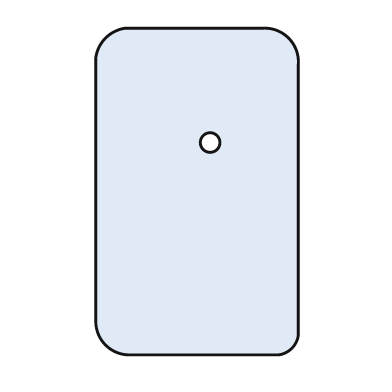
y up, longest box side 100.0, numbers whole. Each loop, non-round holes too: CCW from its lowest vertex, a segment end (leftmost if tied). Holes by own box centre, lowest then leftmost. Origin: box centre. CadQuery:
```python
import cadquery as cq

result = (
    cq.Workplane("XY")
    .moveTo(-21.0, -50.0)
    .lineTo(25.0, -50.0)
    .threePointArc((29.0, -48.0), (31.0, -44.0))
    .lineTo(31.0, 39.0)
    .threePointArc((28.0, 47.0), (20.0, 50.0))
    .lineTo(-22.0, 50.0)
    .threePointArc((-28.0, 47.0), (-31.0, 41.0))
    .lineTo(-31.0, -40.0)
    .threePointArc((-28.0, -47.0), (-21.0, -50.0))
    .close()
    .moveTo(4.0, 15.0)
    .circle(3.0)
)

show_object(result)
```